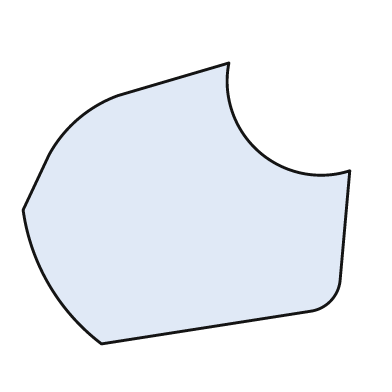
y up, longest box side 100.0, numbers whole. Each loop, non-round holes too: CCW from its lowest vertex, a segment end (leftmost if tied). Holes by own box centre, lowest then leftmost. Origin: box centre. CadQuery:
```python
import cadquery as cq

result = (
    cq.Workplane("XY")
    .moveTo(-26.0, -43.0)
    .lineTo(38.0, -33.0)
    .threePointArc((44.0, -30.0), (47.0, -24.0))
    .lineTo(50.0, 10.0)
    .threePointArc((22.0, 16.0), (13.0, 43.0))
    .lineTo(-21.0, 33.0)
    .threePointArc((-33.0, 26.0), (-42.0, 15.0))
    .lineTo(-50.0, -2.0)
    .threePointArc((-42.0, -25.0), (-26.0, -43.0))
    .close()
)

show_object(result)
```